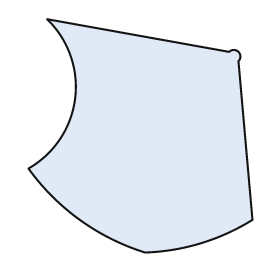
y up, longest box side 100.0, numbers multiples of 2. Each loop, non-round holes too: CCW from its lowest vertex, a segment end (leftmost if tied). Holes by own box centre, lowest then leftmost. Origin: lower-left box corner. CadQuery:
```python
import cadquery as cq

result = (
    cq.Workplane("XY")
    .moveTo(50.0, 0.0)
    .threePointArc((74.0, 4.0), (96.0, 14.0))
    .lineTo(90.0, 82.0)
    .threePointArc((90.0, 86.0), (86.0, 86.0))
    .lineTo(8.0, 100.0)
    .threePointArc((20.0, 66.0), (0.0, 36.0))
    .threePointArc((22.0, 14.0), (50.0, 0.0))
    .close()
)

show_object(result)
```